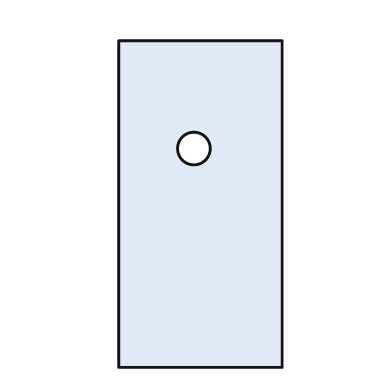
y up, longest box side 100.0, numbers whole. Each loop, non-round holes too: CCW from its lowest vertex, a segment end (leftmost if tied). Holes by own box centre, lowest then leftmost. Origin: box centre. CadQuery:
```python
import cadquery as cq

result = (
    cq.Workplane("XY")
    .moveTo(-25.0, -50.0)
    .lineTo(25.0, -50.0)
    .lineTo(25.0, 50.0)
    .lineTo(-25.0, 50.0)
    .close()
    .moveTo(-2.0, 17.0)
    .circle(5.0)
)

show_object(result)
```